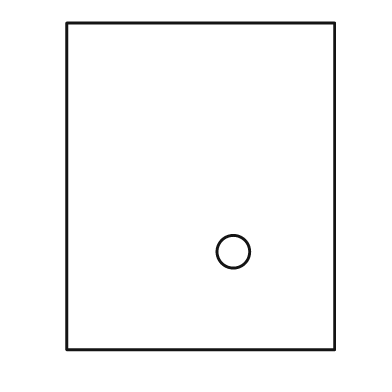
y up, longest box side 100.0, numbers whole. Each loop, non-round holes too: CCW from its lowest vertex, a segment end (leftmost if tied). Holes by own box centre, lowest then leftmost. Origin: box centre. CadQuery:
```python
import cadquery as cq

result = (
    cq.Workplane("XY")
    .moveTo(-41.0, -50.0)
    .lineTo(41.0, -50.0)
    .lineTo(41.0, 50.0)
    .lineTo(-41.0, 50.0)
    .close()
    .moveTo(10.0, -20.0)
    .circle(5.0)
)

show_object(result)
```